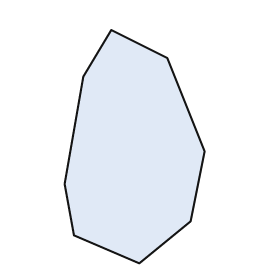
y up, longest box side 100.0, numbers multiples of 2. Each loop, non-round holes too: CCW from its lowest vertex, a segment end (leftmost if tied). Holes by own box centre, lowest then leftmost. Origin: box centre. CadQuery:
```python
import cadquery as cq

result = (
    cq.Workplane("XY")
    .moveTo(2.0, -50.0)
    .lineTo(24.0, -32.0)
    .lineTo(30.0, -2.0)
    .lineTo(14.0, 38.0)
    .lineTo(-10.0, 50.0)
    .lineTo(-22.0, 30.0)
    .lineTo(-30.0, -16.0)
    .lineTo(-26.0, -38.0)
    .close()
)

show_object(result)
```